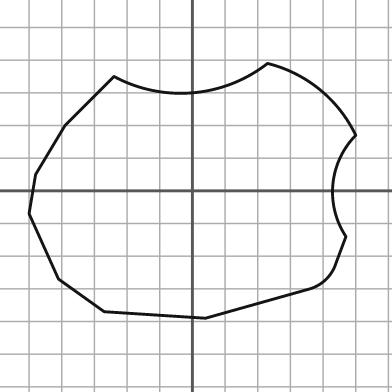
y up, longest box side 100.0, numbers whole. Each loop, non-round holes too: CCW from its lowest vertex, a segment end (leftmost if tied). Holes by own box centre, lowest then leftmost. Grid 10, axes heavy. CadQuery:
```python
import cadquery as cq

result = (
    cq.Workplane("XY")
    .moveTo(4.0, -39.0)
    .lineTo(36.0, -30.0)
    .threePointArc((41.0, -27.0), (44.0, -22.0))
    .lineTo(47.0, -14.0)
    .threePointArc((43.0, 2.0), (50.0, 17.0))
    .threePointArc((39.0, 31.0), (23.0, 39.0))
    .threePointArc((0.0, 30.0), (-24.0, 35.0))
    .lineTo(-39.0, 20.0)
    .lineTo(-48.0, 5.0)
    .lineTo(-50.0, -7.0)
    .lineTo(-41.0, -27.0)
    .lineTo(-27.0, -37.0)
    .close()
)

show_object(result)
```